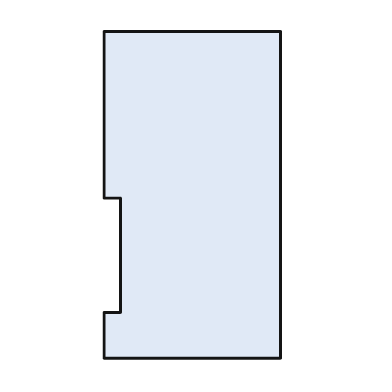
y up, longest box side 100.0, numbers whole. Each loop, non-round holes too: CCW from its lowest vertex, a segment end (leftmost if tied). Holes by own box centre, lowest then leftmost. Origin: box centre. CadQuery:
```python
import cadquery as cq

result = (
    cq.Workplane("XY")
    .moveTo(-27.0, -50.0)
    .lineTo(27.0, -50.0)
    .lineTo(27.0, 50.0)
    .lineTo(-27.0, 50.0)
    .lineTo(-27.0, -1.0)
    .lineTo(-22.0, -1.0)
    .lineTo(-22.0, -36.0)
    .lineTo(-27.0, -36.0)
    .close()
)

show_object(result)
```